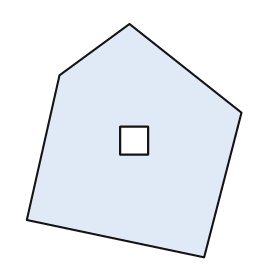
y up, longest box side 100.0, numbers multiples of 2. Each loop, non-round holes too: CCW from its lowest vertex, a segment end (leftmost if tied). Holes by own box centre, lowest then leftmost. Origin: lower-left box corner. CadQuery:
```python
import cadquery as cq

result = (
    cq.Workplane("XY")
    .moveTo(76.0, 0.0)
    .lineTo(92.0, 62.0)
    .lineTo(44.0, 100.0)
    .lineTo(14.0, 78.0)
    .lineTo(0.0, 16.0)
    .close()
    .moveTo(40.0, 44.0)
    .lineTo(52.0, 44.0)
    .lineTo(52.0, 56.0)
    .lineTo(40.0, 56.0)
    .close()
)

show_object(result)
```